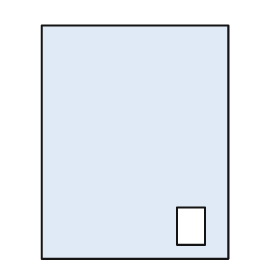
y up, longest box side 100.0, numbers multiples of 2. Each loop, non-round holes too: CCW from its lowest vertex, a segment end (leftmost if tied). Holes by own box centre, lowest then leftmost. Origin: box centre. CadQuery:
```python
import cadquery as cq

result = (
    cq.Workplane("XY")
    .moveTo(-40.0, -50.0)
    .lineTo(40.0, -50.0)
    .lineTo(40.0, 50.0)
    .lineTo(-40.0, 50.0)
    .close()
    .moveTo(18.0, -44.0)
    .lineTo(30.0, -44.0)
    .lineTo(30.0, -28.0)
    .lineTo(18.0, -28.0)
    .close()
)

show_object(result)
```